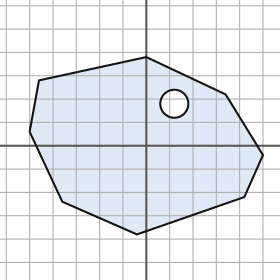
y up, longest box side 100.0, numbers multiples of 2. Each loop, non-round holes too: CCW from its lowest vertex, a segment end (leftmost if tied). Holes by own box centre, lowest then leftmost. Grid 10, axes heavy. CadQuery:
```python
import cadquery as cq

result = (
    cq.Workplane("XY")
    .moveTo(-4.0, -38.0)
    .lineTo(42.0, -22.0)
    .lineTo(50.0, -4.0)
    .lineTo(34.0, 22.0)
    .lineTo(0.0, 38.0)
    .lineTo(-46.0, 28.0)
    .lineTo(-50.0, 6.0)
    .lineTo(-36.0, -24.0)
    .close()
    .moveTo(12.0, 18.0)
    .circle(6.0)
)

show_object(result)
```